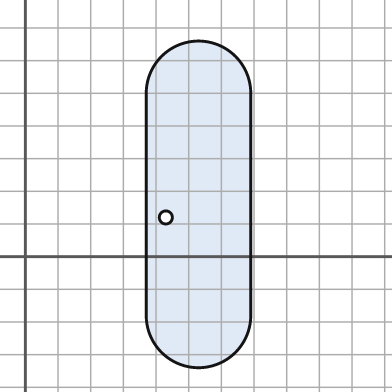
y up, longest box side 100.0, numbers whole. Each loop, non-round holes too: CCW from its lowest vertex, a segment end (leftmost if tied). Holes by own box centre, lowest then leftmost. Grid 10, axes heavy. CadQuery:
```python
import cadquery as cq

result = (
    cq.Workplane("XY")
    .moveTo(37.0, -18.0)
    .threePointArc((53.0, -34.0), (69.0, -18.0))
    .lineTo(69.0, 50.0)
    .threePointArc((53.0, 66.0), (37.0, 50.0))
    .close()
    .moveTo(43.0, 12.0)
    .circle(2.0)
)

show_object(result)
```